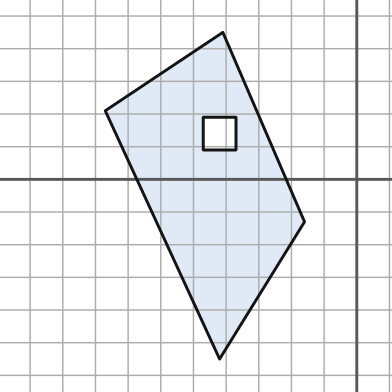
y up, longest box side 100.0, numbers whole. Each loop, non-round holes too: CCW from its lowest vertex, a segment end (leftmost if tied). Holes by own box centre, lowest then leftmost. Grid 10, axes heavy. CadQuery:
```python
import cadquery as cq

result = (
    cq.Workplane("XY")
    .moveTo(-42.0, -55.0)
    .lineTo(-16.0, -13.0)
    .lineTo(-41.0, 45.0)
    .lineTo(-77.0, 21.0)
    .close()
    .moveTo(-47.0, 9.0)
    .lineTo(-37.0, 9.0)
    .lineTo(-37.0, 19.0)
    .lineTo(-47.0, 19.0)
    .close()
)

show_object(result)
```